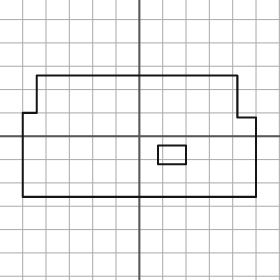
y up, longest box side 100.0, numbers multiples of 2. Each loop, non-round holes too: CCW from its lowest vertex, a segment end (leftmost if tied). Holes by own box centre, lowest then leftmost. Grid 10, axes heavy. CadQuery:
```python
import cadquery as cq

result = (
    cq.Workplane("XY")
    .moveTo(-50.0, -26.0)
    .lineTo(50.0, -26.0)
    .lineTo(50.0, 8.0)
    .lineTo(42.0, 8.0)
    .lineTo(42.0, 26.0)
    .lineTo(-44.0, 26.0)
    .lineTo(-44.0, 10.0)
    .lineTo(-50.0, 10.0)
    .close()
    .moveTo(8.0, -12.0)
    .lineTo(20.0, -12.0)
    .lineTo(20.0, -4.0)
    .lineTo(8.0, -4.0)
    .close()
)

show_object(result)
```